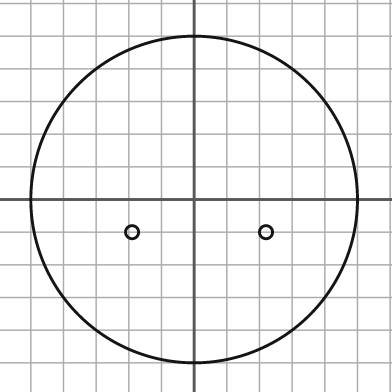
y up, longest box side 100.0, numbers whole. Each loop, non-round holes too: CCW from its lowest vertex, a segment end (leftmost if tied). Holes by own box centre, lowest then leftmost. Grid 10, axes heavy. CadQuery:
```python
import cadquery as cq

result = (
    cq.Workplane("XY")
    .moveTo(0.0, 0.0)
    .circle(50.0)
    .moveTo(-19.0, -10.0)
    .circle(2.0)
    .moveTo(22.0, -10.0)
    .circle(2.0)
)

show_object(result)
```